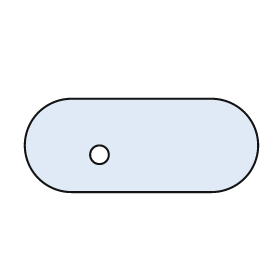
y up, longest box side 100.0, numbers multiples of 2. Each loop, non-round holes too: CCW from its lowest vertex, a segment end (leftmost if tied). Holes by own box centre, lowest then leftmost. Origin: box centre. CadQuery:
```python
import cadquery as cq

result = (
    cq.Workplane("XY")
    .moveTo(-30.0, -20.0)
    .lineTo(30.0, -20.0)
    .threePointArc((50.0, 0.0), (30.0, 20.0))
    .lineTo(-30.0, 20.0)
    .threePointArc((-50.0, 0.0), (-30.0, -20.0))
    .close()
    .moveTo(-18.0, -4.0)
    .circle(4.0)
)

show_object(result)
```